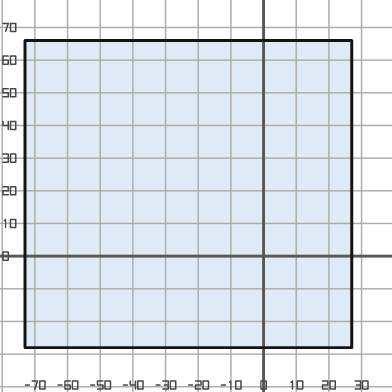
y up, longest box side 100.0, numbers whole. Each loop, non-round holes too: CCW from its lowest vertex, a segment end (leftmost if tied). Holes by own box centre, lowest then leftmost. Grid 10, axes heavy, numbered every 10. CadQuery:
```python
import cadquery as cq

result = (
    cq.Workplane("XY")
    .moveTo(-73.0, -28.0)
    .lineTo(27.0, -28.0)
    .lineTo(27.0, 66.0)
    .lineTo(-73.0, 66.0)
    .close()
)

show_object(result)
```